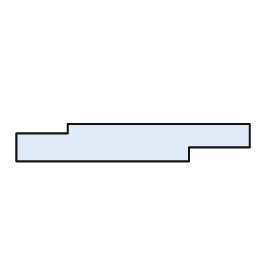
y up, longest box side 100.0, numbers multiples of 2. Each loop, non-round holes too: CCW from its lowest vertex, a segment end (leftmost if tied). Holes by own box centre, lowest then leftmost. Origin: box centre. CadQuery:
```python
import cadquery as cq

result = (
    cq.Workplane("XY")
    .moveTo(-50.0, -8.0)
    .lineTo(24.0, -8.0)
    .lineTo(24.0, -2.0)
    .lineTo(50.0, -2.0)
    .lineTo(50.0, 8.0)
    .lineTo(-28.0, 8.0)
    .lineTo(-28.0, 4.0)
    .lineTo(-50.0, 4.0)
    .close()
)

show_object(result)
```